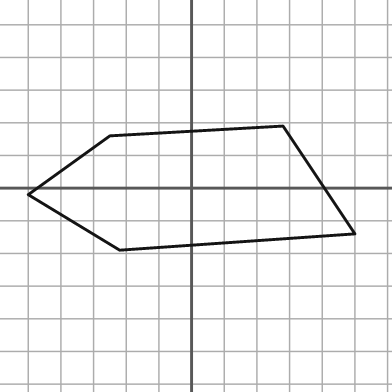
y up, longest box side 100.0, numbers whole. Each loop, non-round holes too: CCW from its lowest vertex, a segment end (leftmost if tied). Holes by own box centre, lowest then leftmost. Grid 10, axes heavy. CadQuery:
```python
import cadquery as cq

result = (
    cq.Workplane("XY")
    .moveTo(-22.0, -19.0)
    .lineTo(50.0, -14.0)
    .lineTo(28.0, 19.0)
    .lineTo(-25.0, 16.0)
    .lineTo(-50.0, -2.0)
    .close()
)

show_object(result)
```